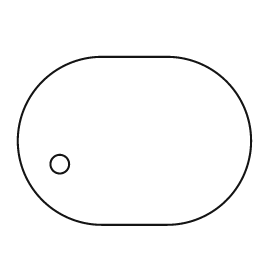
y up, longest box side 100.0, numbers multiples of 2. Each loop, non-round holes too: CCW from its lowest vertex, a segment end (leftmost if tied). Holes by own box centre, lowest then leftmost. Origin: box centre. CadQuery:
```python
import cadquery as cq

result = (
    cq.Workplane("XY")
    .moveTo(-14.0, -36.0)
    .lineTo(14.0, -36.0)
    .threePointArc((50.0, 0.0), (14.0, 36.0))
    .lineTo(-14.0, 36.0)
    .threePointArc((-50.0, 0.0), (-14.0, -36.0))
    .close()
    .moveTo(-32.0, -10.0)
    .circle(4.0)
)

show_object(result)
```